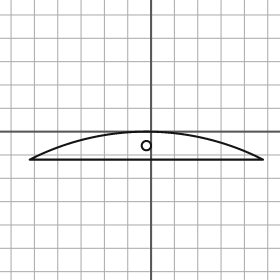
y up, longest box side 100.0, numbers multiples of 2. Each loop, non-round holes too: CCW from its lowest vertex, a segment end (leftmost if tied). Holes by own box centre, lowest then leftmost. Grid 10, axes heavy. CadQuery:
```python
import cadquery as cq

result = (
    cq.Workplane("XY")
    .moveTo(-52.0, -12.0)
    .lineTo(48.0, -12.0)
    .threePointArc((-2.0, 0.0), (-52.0, -12.0))
    .close()
    .moveTo(-2.0, -6.0)
    .circle(2.0)
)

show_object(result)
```